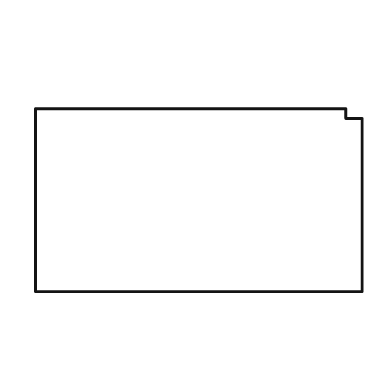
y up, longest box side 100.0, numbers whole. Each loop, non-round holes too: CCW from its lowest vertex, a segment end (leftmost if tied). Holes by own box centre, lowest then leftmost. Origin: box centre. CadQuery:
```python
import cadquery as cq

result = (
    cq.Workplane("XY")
    .moveTo(-50.0, -28.0)
    .lineTo(50.0, -28.0)
    .lineTo(50.0, 25.0)
    .lineTo(45.0, 25.0)
    .lineTo(45.0, 28.0)
    .lineTo(-50.0, 28.0)
    .close()
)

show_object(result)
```